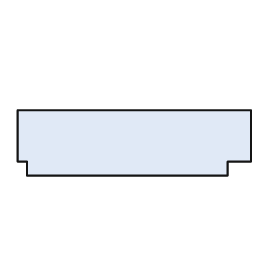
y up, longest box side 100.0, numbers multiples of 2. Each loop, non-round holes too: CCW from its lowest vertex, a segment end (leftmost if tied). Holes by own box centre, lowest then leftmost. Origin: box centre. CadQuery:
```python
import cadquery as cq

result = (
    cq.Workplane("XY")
    .moveTo(-46.0, -14.0)
    .lineTo(40.0, -14.0)
    .lineTo(40.0, -8.0)
    .lineTo(50.0, -8.0)
    .lineTo(50.0, 14.0)
    .lineTo(-50.0, 14.0)
    .lineTo(-50.0, -8.0)
    .lineTo(-46.0, -8.0)
    .close()
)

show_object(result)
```